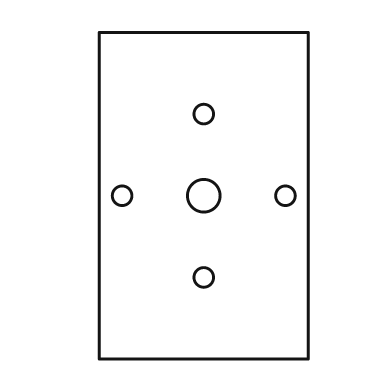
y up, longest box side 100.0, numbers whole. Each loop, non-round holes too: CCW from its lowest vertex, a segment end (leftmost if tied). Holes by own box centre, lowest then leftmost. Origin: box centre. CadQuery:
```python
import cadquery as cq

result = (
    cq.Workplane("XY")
    .moveTo(-32.0, -50.0)
    .lineTo(32.0, -50.0)
    .lineTo(32.0, 50.0)
    .lineTo(-32.0, 50.0)
    .close()
    .moveTo(0.0, -25.0)
    .circle(3.0)
    .moveTo(-25.0, 0.0)
    .circle(3.0)
    .moveTo(0.0, 0.0)
    .circle(5.0)
    .moveTo(25.0, 0.0)
    .circle(3.0)
    .moveTo(0.0, 25.0)
    .circle(3.0)
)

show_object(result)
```